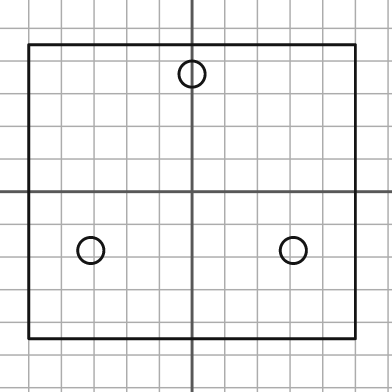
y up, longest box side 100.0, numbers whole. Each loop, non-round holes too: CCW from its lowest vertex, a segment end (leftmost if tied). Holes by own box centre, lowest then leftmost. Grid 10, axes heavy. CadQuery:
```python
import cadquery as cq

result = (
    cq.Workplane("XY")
    .moveTo(-50.0, -45.0)
    .lineTo(50.0, -45.0)
    .lineTo(50.0, 45.0)
    .lineTo(-50.0, 45.0)
    .close()
    .moveTo(-31.0, -18.0)
    .circle(4.0)
    .moveTo(31.0, -18.0)
    .circle(4.0)
    .moveTo(0.0, 36.0)
    .circle(4.0)
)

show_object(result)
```